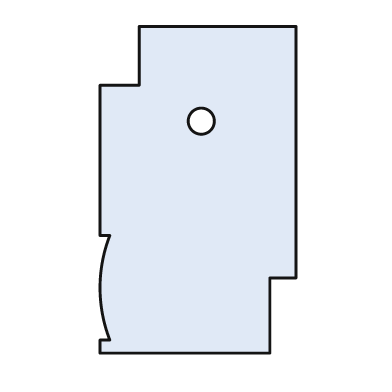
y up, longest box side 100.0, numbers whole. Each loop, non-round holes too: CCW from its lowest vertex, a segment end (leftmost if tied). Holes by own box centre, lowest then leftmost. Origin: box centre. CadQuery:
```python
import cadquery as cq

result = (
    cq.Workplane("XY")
    .moveTo(-30.0, -50.0)
    .lineTo(22.0, -50.0)
    .lineTo(22.0, -27.0)
    .lineTo(30.0, -27.0)
    .lineTo(30.0, 50.0)
    .lineTo(-18.0, 50.0)
    .lineTo(-18.0, 32.0)
    .lineTo(-30.0, 32.0)
    .lineTo(-30.0, -14.0)
    .lineTo(-27.0, -14.0)
    .threePointArc((-30.0, -30.0), (-27.0, -46.0))
    .lineTo(-30.0, -46.0)
    .close()
    .moveTo(1.0, 21.0)
    .circle(4.0)
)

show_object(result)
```